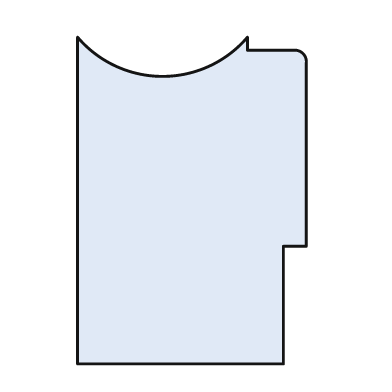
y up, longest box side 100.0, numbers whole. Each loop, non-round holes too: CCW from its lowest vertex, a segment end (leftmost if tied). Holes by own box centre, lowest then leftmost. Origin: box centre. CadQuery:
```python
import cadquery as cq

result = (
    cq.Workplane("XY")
    .moveTo(-35.0, -50.0)
    .lineTo(28.0, -50.0)
    .lineTo(28.0, -14.0)
    .lineTo(35.0, -14.0)
    .lineTo(35.0, 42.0)
    .threePointArc((34.0, 45.0), (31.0, 46.0))
    .lineTo(17.0, 46.0)
    .lineTo(17.0, 50.0)
    .threePointArc((-9.0, 38.0), (-35.0, 50.0))
    .close()
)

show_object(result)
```